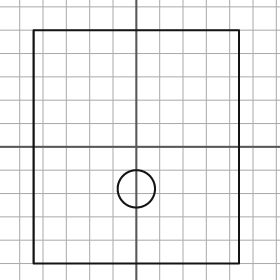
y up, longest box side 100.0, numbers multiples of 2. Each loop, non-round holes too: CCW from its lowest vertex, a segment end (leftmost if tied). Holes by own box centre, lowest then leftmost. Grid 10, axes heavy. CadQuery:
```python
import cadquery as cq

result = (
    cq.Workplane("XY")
    .moveTo(-44.0, -50.0)
    .lineTo(44.0, -50.0)
    .lineTo(44.0, 50.0)
    .lineTo(-44.0, 50.0)
    .close()
    .moveTo(0.0, -18.0)
    .circle(8.0)
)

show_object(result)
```